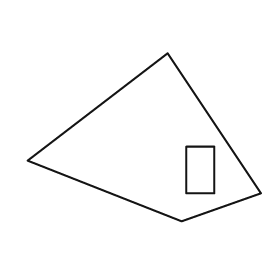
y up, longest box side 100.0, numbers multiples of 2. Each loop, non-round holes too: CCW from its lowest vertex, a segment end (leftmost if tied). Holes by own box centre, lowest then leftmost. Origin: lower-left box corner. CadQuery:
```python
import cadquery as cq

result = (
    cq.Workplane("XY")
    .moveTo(66.0, 0.0)
    .lineTo(100.0, 12.0)
    .lineTo(60.0, 72.0)
    .lineTo(0.0, 26.0)
    .close()
    .moveTo(68.0, 12.0)
    .lineTo(80.0, 12.0)
    .lineTo(80.0, 32.0)
    .lineTo(68.0, 32.0)
    .close()
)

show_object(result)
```